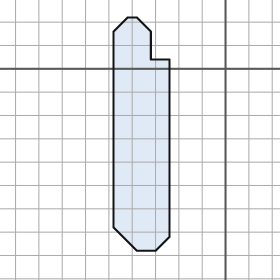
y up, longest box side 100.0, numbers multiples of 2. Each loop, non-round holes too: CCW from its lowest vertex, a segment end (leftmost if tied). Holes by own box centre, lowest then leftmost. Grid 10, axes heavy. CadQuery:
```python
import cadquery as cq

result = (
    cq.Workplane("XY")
    .moveTo(-38.0, -78.0)
    .lineTo(-30.0, -78.0)
    .lineTo(-24.0, -72.0)
    .lineTo(-24.0, 4.0)
    .lineTo(-32.0, 4.0)
    .lineTo(-32.0, 16.0)
    .lineTo(-38.0, 22.0)
    .lineTo(-42.0, 22.0)
    .lineTo(-48.0, 16.0)
    .lineTo(-48.0, -68.0)
    .close()
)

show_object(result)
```